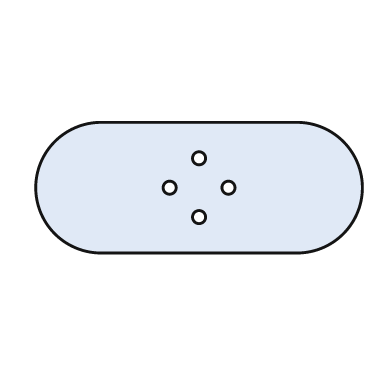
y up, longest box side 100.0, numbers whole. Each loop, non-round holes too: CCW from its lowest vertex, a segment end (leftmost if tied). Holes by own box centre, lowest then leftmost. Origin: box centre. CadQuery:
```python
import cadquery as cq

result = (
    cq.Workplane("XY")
    .moveTo(-30.0, -20.0)
    .lineTo(30.0, -20.0)
    .threePointArc((50.0, 0.0), (30.0, 20.0))
    .lineTo(-30.0, 20.0)
    .threePointArc((-50.0, 0.0), (-30.0, -20.0))
    .close()
    .moveTo(0.0, -9.0)
    .circle(2.0)
    .moveTo(-9.0, 0.0)
    .circle(2.0)
    .moveTo(9.0, 0.0)
    .circle(2.0)
    .moveTo(0.0, 9.0)
    .circle(2.0)
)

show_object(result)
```